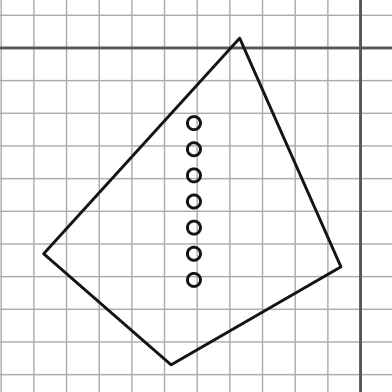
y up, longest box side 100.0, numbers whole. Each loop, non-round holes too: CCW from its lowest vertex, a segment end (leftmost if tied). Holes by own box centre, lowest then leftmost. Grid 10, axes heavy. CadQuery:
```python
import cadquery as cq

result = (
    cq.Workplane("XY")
    .moveTo(-58.0, -97.0)
    .lineTo(-6.0, -67.0)
    .lineTo(-37.0, 3.0)
    .lineTo(-97.0, -63.0)
    .close()
    .moveTo(-51.0, -71.0)
    .circle(2.0)
    .moveTo(-51.0, -63.0)
    .circle(2.0)
    .moveTo(-51.0, -55.0)
    .circle(2.0)
    .moveTo(-51.0, -47.0)
    .circle(2.0)
    .moveTo(-51.0, -39.0)
    .circle(2.0)
    .moveTo(-51.0, -31.0)
    .circle(2.0)
    .moveTo(-51.0, -23.0)
    .circle(2.0)
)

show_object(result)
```